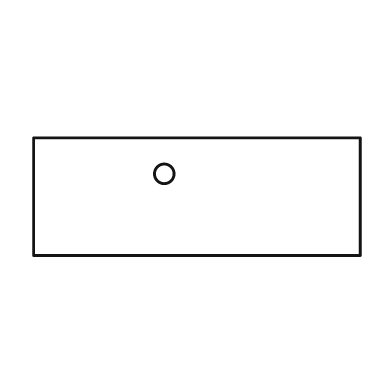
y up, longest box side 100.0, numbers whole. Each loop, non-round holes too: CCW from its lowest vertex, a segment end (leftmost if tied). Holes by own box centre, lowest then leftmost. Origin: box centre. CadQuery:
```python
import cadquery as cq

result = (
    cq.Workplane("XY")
    .moveTo(-50.0, -18.0)
    .lineTo(50.0, -18.0)
    .lineTo(50.0, 18.0)
    .lineTo(-50.0, 18.0)
    .close()
    .moveTo(-10.0, 7.0)
    .circle(3.0)
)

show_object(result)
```